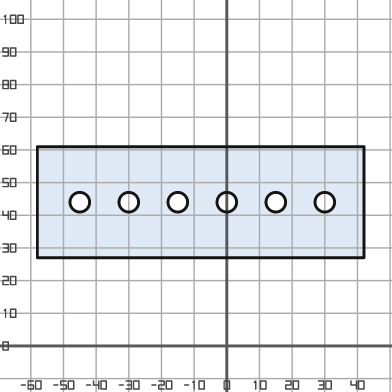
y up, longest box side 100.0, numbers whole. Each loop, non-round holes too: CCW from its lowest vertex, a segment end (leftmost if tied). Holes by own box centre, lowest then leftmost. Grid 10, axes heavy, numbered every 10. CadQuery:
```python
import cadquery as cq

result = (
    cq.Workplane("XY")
    .moveTo(-58.0, 27.0)
    .lineTo(42.0, 27.0)
    .lineTo(42.0, 61.0)
    .lineTo(-58.0, 61.0)
    .close()
    .moveTo(-45.0, 44.0)
    .circle(3.0)
    .moveTo(-30.0, 44.0)
    .circle(3.0)
    .moveTo(-15.0, 44.0)
    .circle(3.0)
    .moveTo(0.0, 44.0)
    .circle(3.0)
    .moveTo(15.0, 44.0)
    .circle(3.0)
    .moveTo(30.0, 44.0)
    .circle(3.0)
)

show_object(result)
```